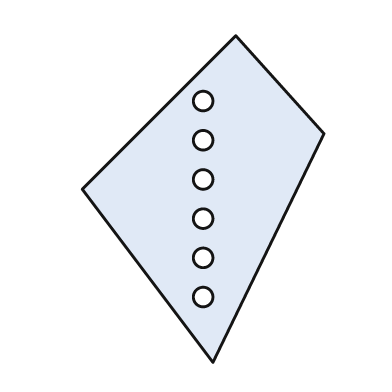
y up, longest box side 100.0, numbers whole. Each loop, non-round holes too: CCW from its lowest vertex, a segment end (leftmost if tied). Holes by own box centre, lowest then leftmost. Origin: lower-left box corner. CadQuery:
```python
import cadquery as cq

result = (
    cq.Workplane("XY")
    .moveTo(40.0, 0.0)
    .lineTo(74.0, 70.0)
    .lineTo(47.0, 100.0)
    .lineTo(0.0, 53.0)
    .close()
    .moveTo(37.0, 20.0)
    .circle(3.0)
    .moveTo(37.0, 32.0)
    .circle(3.0)
    .moveTo(37.0, 44.0)
    .circle(3.0)
    .moveTo(37.0, 56.0)
    .circle(3.0)
    .moveTo(37.0, 68.0)
    .circle(3.0)
    .moveTo(37.0, 80.0)
    .circle(3.0)
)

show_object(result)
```